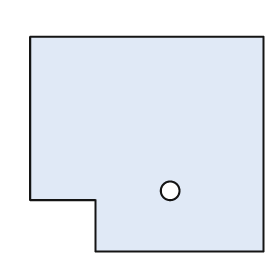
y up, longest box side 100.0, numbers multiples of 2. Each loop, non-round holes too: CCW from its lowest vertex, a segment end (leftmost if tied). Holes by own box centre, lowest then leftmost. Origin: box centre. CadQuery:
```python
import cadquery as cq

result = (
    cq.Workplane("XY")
    .moveTo(-22.0, -46.0)
    .lineTo(50.0, -46.0)
    .lineTo(50.0, 46.0)
    .lineTo(-50.0, 46.0)
    .lineTo(-50.0, -24.0)
    .lineTo(-22.0, -24.0)
    .close()
    .moveTo(10.0, -20.0)
    .circle(4.0)
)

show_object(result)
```